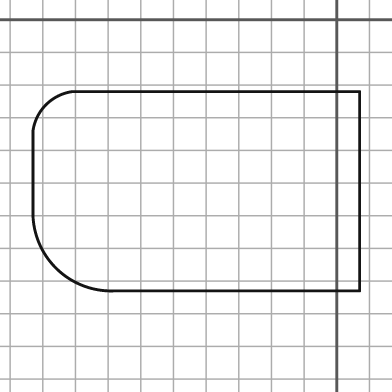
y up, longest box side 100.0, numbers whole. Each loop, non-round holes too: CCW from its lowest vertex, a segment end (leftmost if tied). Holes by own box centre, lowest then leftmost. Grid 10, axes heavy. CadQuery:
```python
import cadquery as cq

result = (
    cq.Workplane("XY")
    .moveTo(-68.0, -83.0)
    .lineTo(7.0, -83.0)
    .lineTo(7.0, -22.0)
    .lineTo(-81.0, -22.0)
    .threePointArc((-89.0, -26.0), (-93.0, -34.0))
    .lineTo(-93.0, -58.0)
    .threePointArc((-86.0, -76.0), (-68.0, -83.0))
    .close()
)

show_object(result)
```